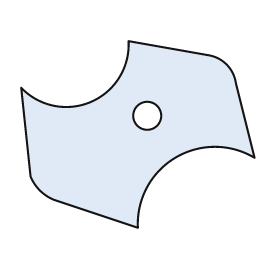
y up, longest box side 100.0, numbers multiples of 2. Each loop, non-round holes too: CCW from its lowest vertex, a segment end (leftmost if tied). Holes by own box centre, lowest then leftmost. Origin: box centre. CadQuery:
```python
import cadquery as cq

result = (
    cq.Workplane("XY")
    .moveTo(0.0, -40.0)
    .threePointArc((16.0, -10.0), (50.0, -10.0))
    .lineTo(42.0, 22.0)
    .threePointArc((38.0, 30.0), (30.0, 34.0))
    .lineTo(-4.0, 40.0)
    .threePointArc((-20.0, 14.0), (-50.0, 20.0))
    .lineTo(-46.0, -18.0)
    .threePointArc((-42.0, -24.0), (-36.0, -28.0))
    .close()
    .moveTo(4.0, 8.0)
    .circle(6.0)
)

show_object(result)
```